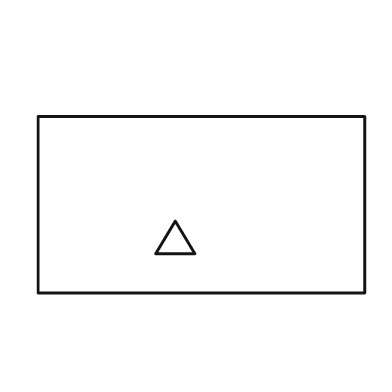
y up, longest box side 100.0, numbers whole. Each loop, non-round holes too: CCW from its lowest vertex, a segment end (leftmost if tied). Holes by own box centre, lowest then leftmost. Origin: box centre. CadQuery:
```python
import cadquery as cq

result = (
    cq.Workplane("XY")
    .moveTo(-50.0, -27.0)
    .lineTo(50.0, -27.0)
    .lineTo(50.0, 27.0)
    .lineTo(-50.0, 27.0)
    .close()
    .moveTo(-14.0, -15.0)
    .lineTo(-2.0, -15.0)
    .lineTo(-8.0, -5.0)
    .close()
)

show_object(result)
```